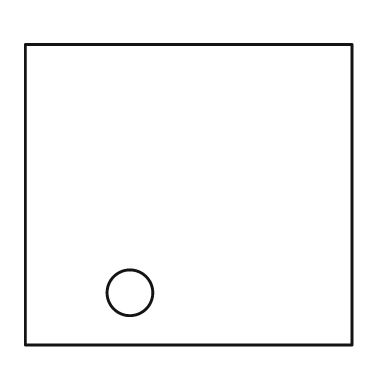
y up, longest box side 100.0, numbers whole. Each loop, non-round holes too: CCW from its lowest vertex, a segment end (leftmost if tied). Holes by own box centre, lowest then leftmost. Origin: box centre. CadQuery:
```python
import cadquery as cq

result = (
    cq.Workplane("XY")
    .moveTo(-50.0, -46.0)
    .lineTo(50.0, -46.0)
    .lineTo(50.0, 46.0)
    .lineTo(-50.0, 46.0)
    .close()
    .moveTo(-18.0, -30.0)
    .circle(7.0)
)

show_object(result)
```